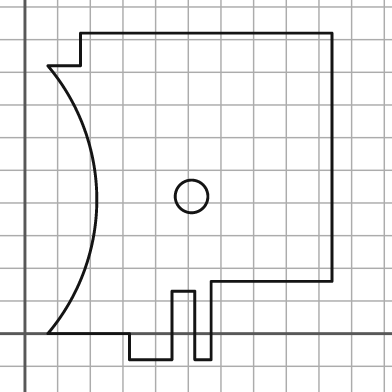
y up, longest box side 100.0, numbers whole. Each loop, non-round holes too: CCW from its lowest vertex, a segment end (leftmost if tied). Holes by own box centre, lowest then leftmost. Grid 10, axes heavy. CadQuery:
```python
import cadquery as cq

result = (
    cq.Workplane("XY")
    .moveTo(32.0, -8.0)
    .lineTo(45.0, -8.0)
    .lineTo(45.0, 13.0)
    .lineTo(52.0, 13.0)
    .lineTo(52.0, -8.0)
    .lineTo(57.0, -8.0)
    .lineTo(57.0, 16.0)
    .lineTo(94.0, 16.0)
    .lineTo(94.0, 92.0)
    .lineTo(17.0, 92.0)
    .lineTo(17.0, 82.0)
    .lineTo(7.0, 82.0)
    .threePointArc((22.0, 41.0), (7.0, 0.0))
    .lineTo(32.0, 0.0)
    .close()
    .moveTo(51.0, 42.0)
    .circle(5.0)
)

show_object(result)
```